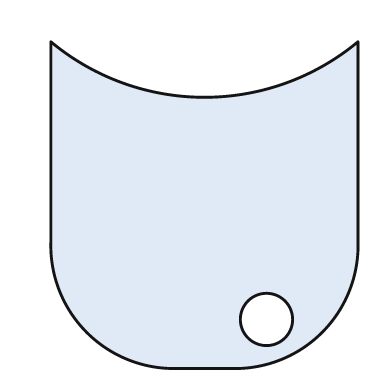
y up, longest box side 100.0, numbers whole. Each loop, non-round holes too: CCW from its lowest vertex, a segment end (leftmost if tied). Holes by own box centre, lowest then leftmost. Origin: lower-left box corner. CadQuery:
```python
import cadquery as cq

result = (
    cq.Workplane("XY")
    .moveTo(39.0, 0.0)
    .lineTo(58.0, 0.0)
    .threePointArc((83.0, 11.0), (94.0, 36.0))
    .lineTo(94.0, 100.0)
    .threePointArc((47.0, 83.0), (0.0, 100.0))
    .lineTo(0.0, 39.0)
    .threePointArc((11.0, 11.0), (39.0, 0.0))
    .close()
    .moveTo(66.0, 15.0)
    .circle(8.0)
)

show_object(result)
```